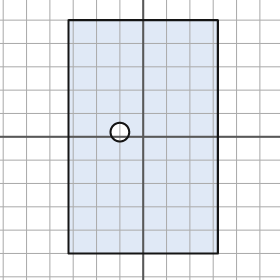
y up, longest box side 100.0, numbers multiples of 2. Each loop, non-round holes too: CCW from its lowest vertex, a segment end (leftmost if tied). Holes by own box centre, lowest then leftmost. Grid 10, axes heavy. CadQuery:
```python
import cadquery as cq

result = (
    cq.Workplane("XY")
    .moveTo(-32.0, -50.0)
    .lineTo(32.0, -50.0)
    .lineTo(32.0, 50.0)
    .lineTo(-32.0, 50.0)
    .close()
    .moveTo(-10.0, 2.0)
    .circle(4.0)
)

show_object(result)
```